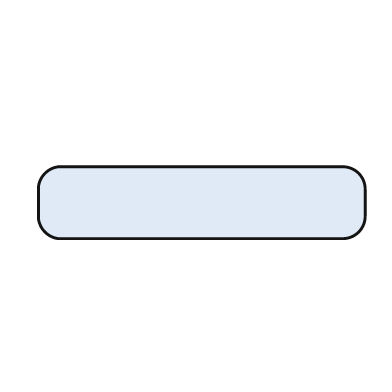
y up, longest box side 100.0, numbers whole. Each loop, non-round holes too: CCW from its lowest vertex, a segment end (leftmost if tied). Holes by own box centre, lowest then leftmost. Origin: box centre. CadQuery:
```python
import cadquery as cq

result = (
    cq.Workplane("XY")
    .moveTo(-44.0, -11.0)
    .lineTo(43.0, -11.0)
    .threePointArc((48.0, -9.0), (50.0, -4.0))
    .lineTo(50.0, 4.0)
    .threePointArc((48.0, 9.0), (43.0, 11.0))
    .lineTo(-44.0, 11.0)
    .threePointArc((-48.0, 9.0), (-50.0, 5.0))
    .lineTo(-50.0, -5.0)
    .threePointArc((-48.0, -9.0), (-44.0, -11.0))
    .close()
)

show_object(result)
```